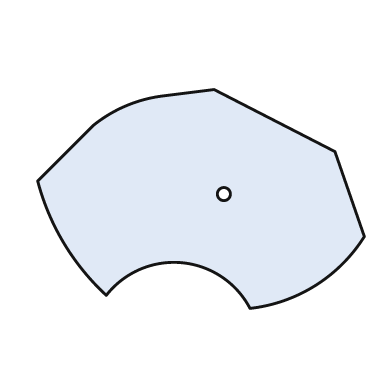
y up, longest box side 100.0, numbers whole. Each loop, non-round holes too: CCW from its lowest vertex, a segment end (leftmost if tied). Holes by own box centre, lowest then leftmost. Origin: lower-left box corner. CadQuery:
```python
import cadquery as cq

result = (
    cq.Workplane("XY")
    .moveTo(65.0, 0.0)
    .threePointArc((85.0, 7.0), (100.0, 22.0))
    .lineTo(91.0, 48.0)
    .lineTo(54.0, 67.0)
    .lineTo(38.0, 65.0)
    .threePointArc((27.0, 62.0), (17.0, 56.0))
    .lineTo(0.0, 39.0)
    .threePointArc((8.0, 20.0), (21.0, 4.0))
    .threePointArc((44.0, 14.0), (65.0, 0.0))
    .close()
    .moveTo(57.0, 35.0)
    .circle(2.0)
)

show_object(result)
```